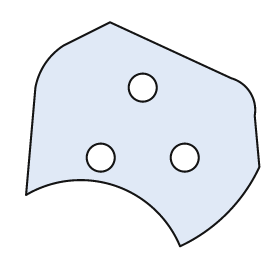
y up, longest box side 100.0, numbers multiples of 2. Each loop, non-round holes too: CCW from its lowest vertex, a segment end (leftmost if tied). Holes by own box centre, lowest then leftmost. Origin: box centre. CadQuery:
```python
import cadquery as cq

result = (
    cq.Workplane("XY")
    .moveTo(16.0, -48.0)
    .threePointArc((36.0, -34.0), (50.0, -14.0))
    .lineTo(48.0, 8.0)
    .threePointArc((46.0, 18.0), (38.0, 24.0))
    .lineTo(-14.0, 48.0)
    .lineTo(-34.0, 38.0)
    .threePointArc((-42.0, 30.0), (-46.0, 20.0))
    .lineTo(-50.0, -26.0)
    .threePointArc((-12.0, -22.0), (16.0, -48.0))
    .close()
    .moveTo(-18.0, -10.0)
    .circle(6.0)
    .moveTo(18.0, -10.0)
    .circle(6.0)
    .moveTo(0.0, 20.0)
    .circle(6.0)
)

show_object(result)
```